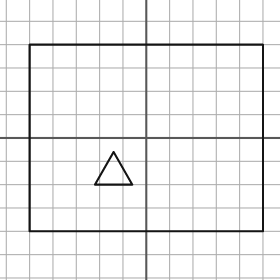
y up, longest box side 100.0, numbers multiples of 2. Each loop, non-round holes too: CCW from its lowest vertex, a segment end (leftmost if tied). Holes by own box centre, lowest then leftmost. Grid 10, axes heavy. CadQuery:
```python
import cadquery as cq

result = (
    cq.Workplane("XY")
    .moveTo(-50.0, -40.0)
    .lineTo(50.0, -40.0)
    .lineTo(50.0, 40.0)
    .lineTo(-50.0, 40.0)
    .close()
    .moveTo(-22.0, -20.0)
    .lineTo(-6.0, -20.0)
    .lineTo(-14.0, -6.0)
    .close()
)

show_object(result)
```